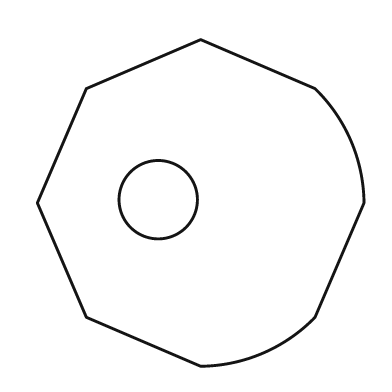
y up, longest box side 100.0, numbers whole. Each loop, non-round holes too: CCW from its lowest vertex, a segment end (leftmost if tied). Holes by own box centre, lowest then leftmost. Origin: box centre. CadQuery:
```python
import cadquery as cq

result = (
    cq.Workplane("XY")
    .moveTo(0.0, -50.0)
    .threePointArc((19.0, -46.0), (35.0, -35.0))
    .lineTo(50.0, 0.0)
    .threePointArc((46.0, 19.0), (35.0, 35.0))
    .lineTo(0.0, 50.0)
    .lineTo(-35.0, 35.0)
    .lineTo(-50.0, 0.0)
    .lineTo(-35.0, -35.0)
    .close()
    .moveTo(-13.0, 1.0)
    .circle(12.0)
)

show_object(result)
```